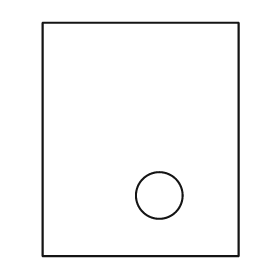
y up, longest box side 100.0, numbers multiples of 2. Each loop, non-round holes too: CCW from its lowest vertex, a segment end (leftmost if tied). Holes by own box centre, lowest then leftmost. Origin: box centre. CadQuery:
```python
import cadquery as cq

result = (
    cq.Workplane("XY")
    .moveTo(-42.0, -50.0)
    .lineTo(42.0, -50.0)
    .lineTo(42.0, 50.0)
    .lineTo(-42.0, 50.0)
    .close()
    .moveTo(8.0, -24.0)
    .circle(10.0)
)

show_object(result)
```